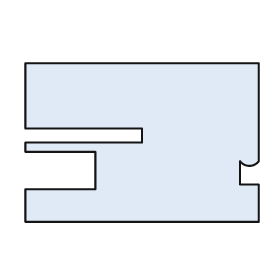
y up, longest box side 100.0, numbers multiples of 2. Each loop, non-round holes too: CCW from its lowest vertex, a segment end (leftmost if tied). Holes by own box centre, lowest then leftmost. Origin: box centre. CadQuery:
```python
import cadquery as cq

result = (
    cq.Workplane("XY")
    .moveTo(-50.0, -34.0)
    .lineTo(50.0, -34.0)
    .lineTo(50.0, -18.0)
    .lineTo(42.0, -18.0)
    .lineTo(42.0, -8.0)
    .threePointArc((46.0, -10.0), (50.0, -8.0))
    .lineTo(50.0, 34.0)
    .lineTo(-50.0, 34.0)
    .lineTo(-50.0, 6.0)
    .lineTo(0.0, 6.0)
    .lineTo(0.0, 0.0)
    .lineTo(-50.0, 0.0)
    .lineTo(-50.0, -4.0)
    .lineTo(-20.0, -4.0)
    .lineTo(-20.0, -20.0)
    .lineTo(-50.0, -20.0)
    .close()
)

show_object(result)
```